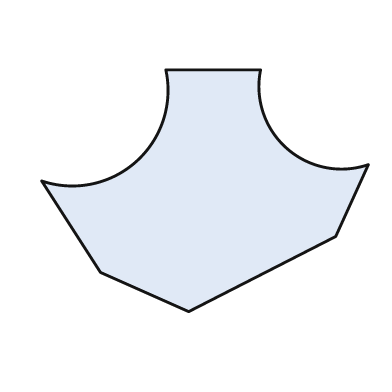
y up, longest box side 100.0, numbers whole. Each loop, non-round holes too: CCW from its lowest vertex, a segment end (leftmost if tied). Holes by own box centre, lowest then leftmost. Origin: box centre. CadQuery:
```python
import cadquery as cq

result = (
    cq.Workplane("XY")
    .moveTo(-5.0, -37.0)
    .lineTo(40.0, -14.0)
    .lineTo(50.0, 8.0)
    .threePointArc((25.0, 13.0), (17.0, 37.0))
    .lineTo(-12.0, 37.0)
    .threePointArc((-21.0, 9.0), (-50.0, 3.0))
    .lineTo(-32.0, -25.0)
    .close()
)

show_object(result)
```